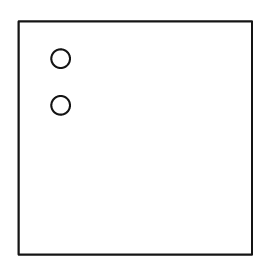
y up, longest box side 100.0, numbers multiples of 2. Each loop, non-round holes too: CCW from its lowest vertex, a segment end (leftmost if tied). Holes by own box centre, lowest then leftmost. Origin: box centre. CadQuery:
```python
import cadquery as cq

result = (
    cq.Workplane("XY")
    .moveTo(-50.0, -50.0)
    .lineTo(50.0, -50.0)
    .lineTo(50.0, 50.0)
    .lineTo(-50.0, 50.0)
    .close()
    .moveTo(-32.0, 14.0)
    .circle(4.0)
    .moveTo(-32.0, 34.0)
    .circle(4.0)
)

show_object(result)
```